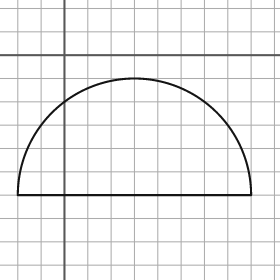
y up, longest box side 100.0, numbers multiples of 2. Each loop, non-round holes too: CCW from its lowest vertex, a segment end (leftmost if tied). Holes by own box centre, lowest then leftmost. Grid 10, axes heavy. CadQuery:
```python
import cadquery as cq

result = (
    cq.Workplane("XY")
    .moveTo(-20.0, -60.0)
    .lineTo(80.0, -60.0)
    .threePointArc((30.0, -10.0), (-20.0, -60.0))
    .close()
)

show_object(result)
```